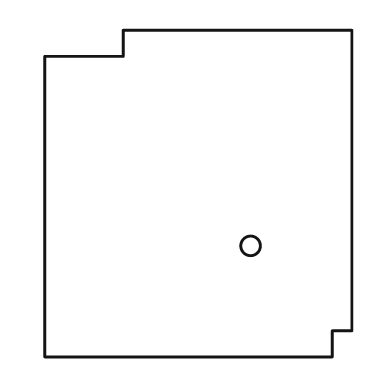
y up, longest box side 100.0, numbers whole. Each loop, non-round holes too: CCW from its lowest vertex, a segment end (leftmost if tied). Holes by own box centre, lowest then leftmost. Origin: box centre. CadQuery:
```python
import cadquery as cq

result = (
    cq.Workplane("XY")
    .moveTo(-47.0, -50.0)
    .lineTo(41.0, -50.0)
    .lineTo(41.0, -42.0)
    .lineTo(47.0, -42.0)
    .lineTo(47.0, 50.0)
    .lineTo(-23.0, 50.0)
    .lineTo(-23.0, 42.0)
    .lineTo(-47.0, 42.0)
    .close()
    .moveTo(16.0, -16.0)
    .circle(3.0)
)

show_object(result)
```